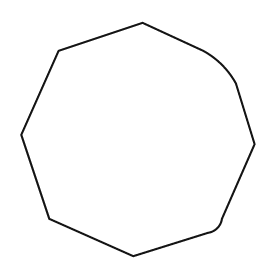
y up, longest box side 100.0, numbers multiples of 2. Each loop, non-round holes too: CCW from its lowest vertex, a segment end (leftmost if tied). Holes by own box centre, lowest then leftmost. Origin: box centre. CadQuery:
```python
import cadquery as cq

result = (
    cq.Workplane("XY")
    .moveTo(-2.0, -50.0)
    .lineTo(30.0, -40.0)
    .threePointArc((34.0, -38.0), (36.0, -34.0))
    .lineTo(50.0, -2.0)
    .lineTo(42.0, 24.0)
    .threePointArc((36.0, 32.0), (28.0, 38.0))
    .lineTo(2.0, 50.0)
    .lineTo(-34.0, 38.0)
    .lineTo(-50.0, 2.0)
    .lineTo(-38.0, -34.0)
    .close()
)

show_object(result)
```